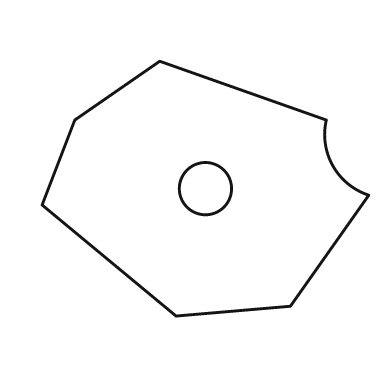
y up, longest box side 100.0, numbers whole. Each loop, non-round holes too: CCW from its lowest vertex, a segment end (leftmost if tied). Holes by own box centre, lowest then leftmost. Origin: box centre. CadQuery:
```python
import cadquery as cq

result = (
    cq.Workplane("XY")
    .moveTo(-9.0, -39.0)
    .lineTo(26.0, -36.0)
    .lineTo(50.0, -2.0)
    .threePointArc((39.0, 7.0), (37.0, 21.0))
    .lineTo(-14.0, 39.0)
    .lineTo(-40.0, 21.0)
    .lineTo(-50.0, -5.0)
    .close()
    .moveTo(0.0, 0.0)
    .circle(8.0)
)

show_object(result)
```